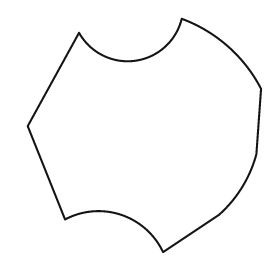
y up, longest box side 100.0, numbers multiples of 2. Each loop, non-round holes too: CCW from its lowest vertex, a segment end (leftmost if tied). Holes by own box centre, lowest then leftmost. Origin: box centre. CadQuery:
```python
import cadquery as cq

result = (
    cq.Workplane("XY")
    .moveTo(8.0, -50.0)
    .lineTo(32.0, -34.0)
    .threePointArc((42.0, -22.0), (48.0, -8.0))
    .lineTo(50.0, 20.0)
    .threePointArc((36.0, 38.0), (16.0, 50.0))
    .threePointArc((-4.0, 32.0), (-28.0, 44.0))
    .lineTo(-50.0, 4.0)
    .lineTo(-34.0, -36.0)
    .threePointArc((-10.0, -34.0), (8.0, -50.0))
    .close()
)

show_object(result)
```